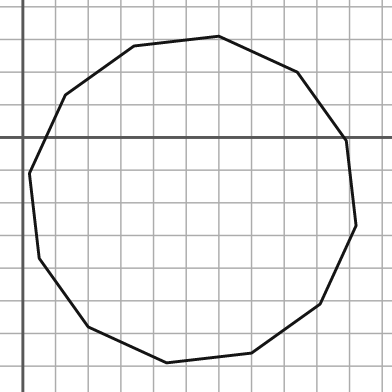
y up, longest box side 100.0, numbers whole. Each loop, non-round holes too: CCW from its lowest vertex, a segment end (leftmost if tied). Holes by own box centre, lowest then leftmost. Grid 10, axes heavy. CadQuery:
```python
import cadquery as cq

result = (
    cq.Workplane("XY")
    .moveTo(44.0, -69.0)
    .lineTo(70.0, -66.0)
    .lineTo(91.0, -51.0)
    .lineTo(102.0, -27.0)
    .lineTo(99.0, -1.0)
    .lineTo(84.0, 20.0)
    .lineTo(60.0, 31.0)
    .lineTo(34.0, 28.0)
    .lineTo(13.0, 13.0)
    .lineTo(2.0, -11.0)
    .lineTo(5.0, -37.0)
    .lineTo(20.0, -58.0)
    .close()
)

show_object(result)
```